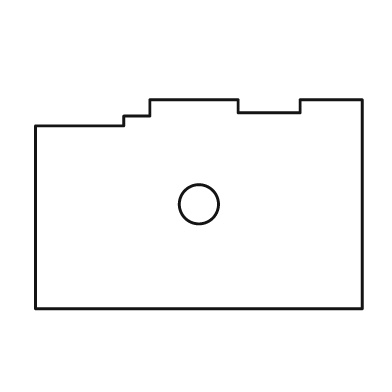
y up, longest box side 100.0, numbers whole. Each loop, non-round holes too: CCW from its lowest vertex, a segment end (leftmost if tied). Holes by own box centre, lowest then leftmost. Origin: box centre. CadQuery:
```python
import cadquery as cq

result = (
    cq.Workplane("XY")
    .moveTo(-50.0, -32.0)
    .lineTo(50.0, -32.0)
    .lineTo(50.0, 32.0)
    .lineTo(31.0, 32.0)
    .lineTo(31.0, 28.0)
    .lineTo(12.0, 28.0)
    .lineTo(12.0, 32.0)
    .lineTo(-15.0, 32.0)
    .lineTo(-15.0, 27.0)
    .lineTo(-23.0, 27.0)
    .lineTo(-23.0, 24.0)
    .lineTo(-50.0, 24.0)
    .close()
    .moveTo(0.0, 0.0)
    .circle(6.0)
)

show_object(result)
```